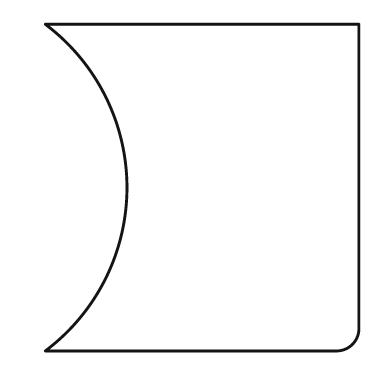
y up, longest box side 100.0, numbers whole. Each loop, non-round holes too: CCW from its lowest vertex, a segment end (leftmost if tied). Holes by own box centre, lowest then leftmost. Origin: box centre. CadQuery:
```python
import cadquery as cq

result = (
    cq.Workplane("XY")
    .moveTo(-48.0, -50.0)
    .lineTo(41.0, -50.0)
    .threePointArc((46.0, -48.0), (48.0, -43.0))
    .lineTo(48.0, 50.0)
    .lineTo(-48.0, 50.0)
    .threePointArc((-23.0, 0.0), (-48.0, -50.0))
    .close()
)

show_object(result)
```